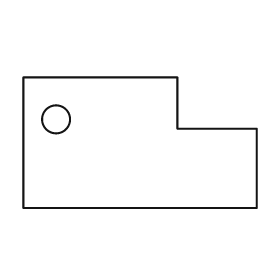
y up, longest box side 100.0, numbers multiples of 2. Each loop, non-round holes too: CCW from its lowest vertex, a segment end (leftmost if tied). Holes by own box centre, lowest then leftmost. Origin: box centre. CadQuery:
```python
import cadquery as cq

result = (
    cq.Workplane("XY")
    .moveTo(-50.0, -28.0)
    .lineTo(50.0, -28.0)
    .lineTo(50.0, 6.0)
    .lineTo(16.0, 6.0)
    .lineTo(16.0, 28.0)
    .lineTo(-50.0, 28.0)
    .close()
    .moveTo(-36.0, 10.0)
    .circle(6.0)
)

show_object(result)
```